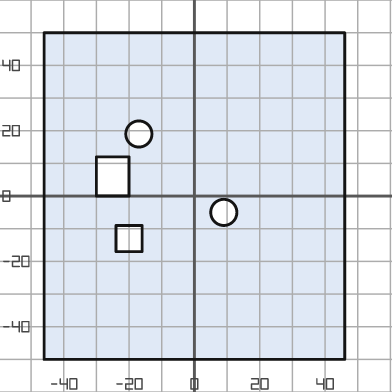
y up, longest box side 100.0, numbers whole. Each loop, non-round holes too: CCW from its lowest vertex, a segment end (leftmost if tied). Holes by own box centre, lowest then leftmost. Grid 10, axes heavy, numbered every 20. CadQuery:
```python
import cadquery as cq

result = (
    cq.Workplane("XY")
    .moveTo(-46.0, -50.0)
    .lineTo(46.0, -50.0)
    .lineTo(46.0, 50.0)
    .lineTo(-46.0, 50.0)
    .close()
    .moveTo(-24.0, -17.0)
    .lineTo(-16.0, -17.0)
    .lineTo(-16.0, -9.0)
    .lineTo(-24.0, -9.0)
    .close()
    .moveTo(9.0, -5.0)
    .circle(4.0)
    .moveTo(-30.0, 0.0)
    .lineTo(-20.0, 0.0)
    .lineTo(-20.0, 12.0)
    .lineTo(-30.0, 12.0)
    .close()
    .moveTo(-17.0, 19.0)
    .circle(4.0)
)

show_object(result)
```